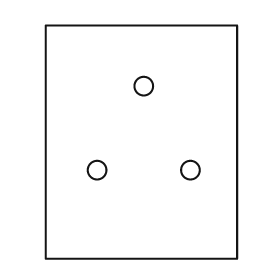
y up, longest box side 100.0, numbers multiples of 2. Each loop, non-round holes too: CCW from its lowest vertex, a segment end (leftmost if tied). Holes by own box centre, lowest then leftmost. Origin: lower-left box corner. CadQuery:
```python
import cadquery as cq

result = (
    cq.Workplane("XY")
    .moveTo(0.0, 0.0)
    .lineTo(82.0, 0.0)
    .lineTo(82.0, 100.0)
    .lineTo(0.0, 100.0)
    .close()
    .moveTo(22.0, 38.0)
    .circle(4.0)
    .moveTo(62.0, 38.0)
    .circle(4.0)
    .moveTo(42.0, 74.0)
    .circle(4.0)
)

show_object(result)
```